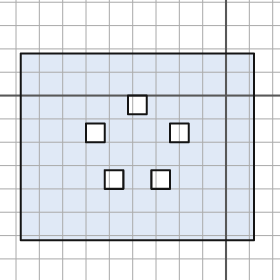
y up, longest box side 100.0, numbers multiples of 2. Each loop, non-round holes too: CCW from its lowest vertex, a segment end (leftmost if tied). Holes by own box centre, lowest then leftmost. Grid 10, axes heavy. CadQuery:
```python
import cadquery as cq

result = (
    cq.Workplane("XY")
    .moveTo(-88.0, -62.0)
    .lineTo(12.0, -62.0)
    .lineTo(12.0, 18.0)
    .lineTo(-88.0, 18.0)
    .close()
    .moveTo(-52.0, -40.0)
    .lineTo(-44.0, -40.0)
    .lineTo(-44.0, -32.0)
    .lineTo(-52.0, -32.0)
    .close()
    .moveTo(-32.0, -40.0)
    .lineTo(-24.0, -40.0)
    .lineTo(-24.0, -32.0)
    .lineTo(-32.0, -32.0)
    .close()
    .moveTo(-60.0, -20.0)
    .lineTo(-52.0, -20.0)
    .lineTo(-52.0, -12.0)
    .lineTo(-60.0, -12.0)
    .close()
    .moveTo(-24.0, -20.0)
    .lineTo(-16.0, -20.0)
    .lineTo(-16.0, -12.0)
    .lineTo(-24.0, -12.0)
    .close()
    .moveTo(-42.0, -8.0)
    .lineTo(-34.0, -8.0)
    .lineTo(-34.0, 0.0)
    .lineTo(-42.0, 0.0)
    .close()
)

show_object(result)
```